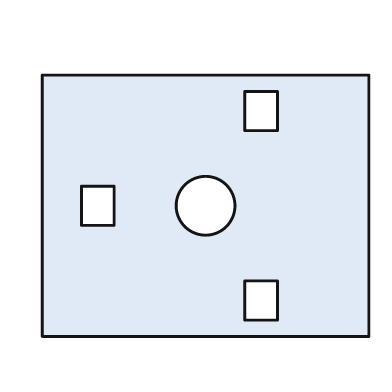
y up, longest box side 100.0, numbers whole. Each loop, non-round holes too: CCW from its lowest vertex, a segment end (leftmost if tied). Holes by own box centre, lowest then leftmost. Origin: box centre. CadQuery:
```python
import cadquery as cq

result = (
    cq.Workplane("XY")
    .moveTo(-50.0, -40.0)
    .lineTo(50.0, -40.0)
    .lineTo(50.0, 40.0)
    .lineTo(-50.0, 40.0)
    .close()
    .moveTo(12.0, -35.0)
    .lineTo(22.0, -35.0)
    .lineTo(22.0, -23.0)
    .lineTo(12.0, -23.0)
    .close()
    .moveTo(-38.0, -6.0)
    .lineTo(-28.0, -6.0)
    .lineTo(-28.0, 6.0)
    .lineTo(-38.0, 6.0)
    .close()
    .moveTo(0.0, 0.0)
    .circle(9.0)
    .moveTo(12.0, 23.0)
    .lineTo(22.0, 23.0)
    .lineTo(22.0, 35.0)
    .lineTo(12.0, 35.0)
    .close()
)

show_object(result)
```